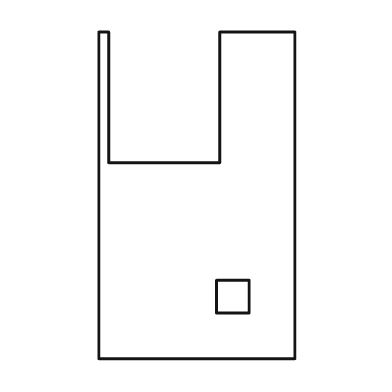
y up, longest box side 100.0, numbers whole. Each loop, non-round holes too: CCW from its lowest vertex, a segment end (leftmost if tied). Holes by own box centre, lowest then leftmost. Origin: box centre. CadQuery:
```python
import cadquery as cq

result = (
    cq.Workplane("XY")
    .moveTo(-30.0, -50.0)
    .lineTo(30.0, -50.0)
    .lineTo(30.0, 50.0)
    .lineTo(7.0, 50.0)
    .lineTo(7.0, 10.0)
    .lineTo(-27.0, 10.0)
    .lineTo(-27.0, 50.0)
    .lineTo(-30.0, 50.0)
    .close()
    .moveTo(6.0, -36.0)
    .lineTo(16.0, -36.0)
    .lineTo(16.0, -26.0)
    .lineTo(6.0, -26.0)
    .close()
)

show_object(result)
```